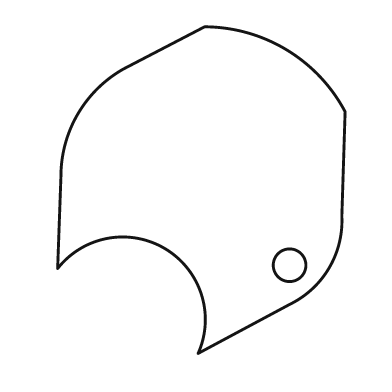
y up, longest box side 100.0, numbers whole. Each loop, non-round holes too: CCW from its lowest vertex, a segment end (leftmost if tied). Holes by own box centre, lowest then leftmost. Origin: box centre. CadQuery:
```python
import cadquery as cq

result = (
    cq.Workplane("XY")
    .moveTo(-1.0, -50.0)
    .lineTo(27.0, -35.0)
    .threePointArc((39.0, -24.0), (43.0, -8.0))
    .lineTo(44.0, 24.0)
    .threePointArc((26.0, 43.0), (1.0, 50.0))
    .lineTo(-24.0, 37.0)
    .threePointArc((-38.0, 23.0), (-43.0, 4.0))
    .lineTo(-44.0, -24.0)
    .threePointArc((-11.0, -18.0), (-1.0, -50.0))
    .close()
    .moveTo(27.0, -23.0)
    .circle(5.0)
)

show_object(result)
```